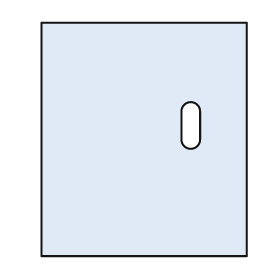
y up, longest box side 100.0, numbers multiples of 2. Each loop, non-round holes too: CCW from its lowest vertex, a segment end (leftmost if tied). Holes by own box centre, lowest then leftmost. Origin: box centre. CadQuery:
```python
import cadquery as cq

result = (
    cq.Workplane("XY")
    .moveTo(-44.0, -50.0)
    .lineTo(44.0, -50.0)
    .lineTo(44.0, 50.0)
    .lineTo(-44.0, 50.0)
    .close()
    .moveTo(16.0, 0.0)
    .threePointArc((20.0, -4.0), (24.0, 0.0))
    .lineTo(24.0, 12.0)
    .threePointArc((20.0, 16.0), (16.0, 12.0))
    .close()
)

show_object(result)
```